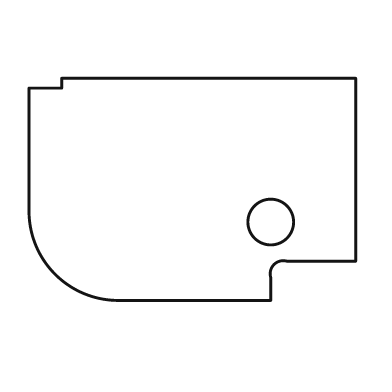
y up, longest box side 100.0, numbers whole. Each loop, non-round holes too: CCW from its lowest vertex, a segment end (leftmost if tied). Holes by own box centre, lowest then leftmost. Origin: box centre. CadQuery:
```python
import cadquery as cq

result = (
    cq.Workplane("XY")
    .moveTo(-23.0, -34.0)
    .lineTo(24.0, -34.0)
    .lineTo(24.0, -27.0)
    .threePointArc((25.0, -23.0), (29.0, -22.0))
    .lineTo(50.0, -22.0)
    .lineTo(50.0, 34.0)
    .lineTo(-40.0, 34.0)
    .lineTo(-40.0, 31.0)
    .lineTo(-50.0, 31.0)
    .lineTo(-50.0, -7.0)
    .threePointArc((-42.0, -26.0), (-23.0, -34.0))
    .close()
    .moveTo(24.0, -10.0)
    .circle(7.0)
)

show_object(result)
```